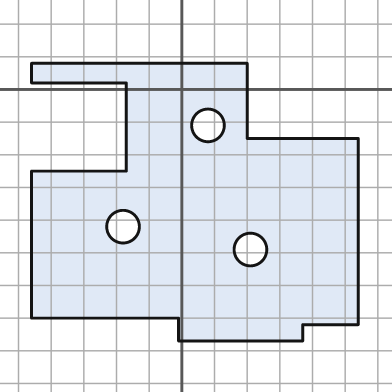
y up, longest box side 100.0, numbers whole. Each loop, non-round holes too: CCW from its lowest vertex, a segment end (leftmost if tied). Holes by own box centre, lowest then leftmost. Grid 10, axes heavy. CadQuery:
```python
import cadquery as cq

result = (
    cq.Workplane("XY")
    .moveTo(-1.0, -77.0)
    .lineTo(37.0, -77.0)
    .lineTo(37.0, -72.0)
    .lineTo(54.0, -72.0)
    .lineTo(54.0, -15.0)
    .lineTo(20.0, -15.0)
    .lineTo(20.0, 8.0)
    .lineTo(-46.0, 8.0)
    .lineTo(-46.0, 2.0)
    .lineTo(-17.0, 2.0)
    .lineTo(-17.0, -25.0)
    .lineTo(-46.0, -25.0)
    .lineTo(-46.0, -70.0)
    .lineTo(-1.0, -70.0)
    .close()
    .moveTo(21.0, -49.0)
    .circle(5.0)
    .moveTo(-18.0, -42.0)
    .circle(5.0)
    .moveTo(8.0, -11.0)
    .circle(5.0)
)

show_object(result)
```